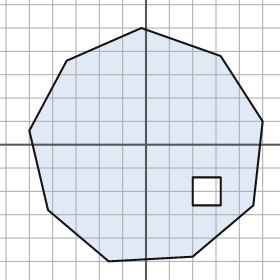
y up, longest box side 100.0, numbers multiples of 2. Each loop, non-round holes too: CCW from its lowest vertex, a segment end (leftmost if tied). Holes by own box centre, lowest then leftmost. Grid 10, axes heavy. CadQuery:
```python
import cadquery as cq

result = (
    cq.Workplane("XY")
    .moveTo(-16.0, -50.0)
    .lineTo(20.0, -48.0)
    .lineTo(46.0, -26.0)
    .lineTo(50.0, 10.0)
    .lineTo(32.0, 38.0)
    .lineTo(-2.0, 50.0)
    .lineTo(-34.0, 36.0)
    .lineTo(-50.0, 6.0)
    .lineTo(-42.0, -28.0)
    .close()
    .moveTo(20.0, -26.0)
    .lineTo(32.0, -26.0)
    .lineTo(32.0, -14.0)
    .lineTo(20.0, -14.0)
    .close()
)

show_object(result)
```